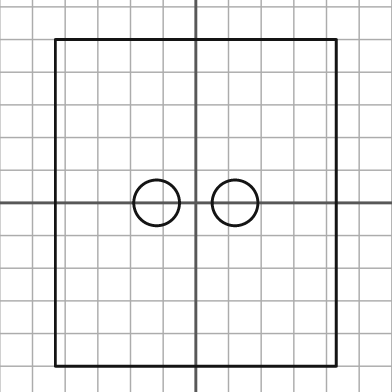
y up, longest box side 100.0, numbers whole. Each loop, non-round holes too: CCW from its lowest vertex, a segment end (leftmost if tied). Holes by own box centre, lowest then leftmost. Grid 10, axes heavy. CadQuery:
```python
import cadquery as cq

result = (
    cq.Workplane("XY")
    .moveTo(-43.0, -50.0)
    .lineTo(43.0, -50.0)
    .lineTo(43.0, 50.0)
    .lineTo(-43.0, 50.0)
    .close()
    .moveTo(-12.0, 0.0)
    .circle(7.0)
    .moveTo(12.0, 0.0)
    .circle(7.0)
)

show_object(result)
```